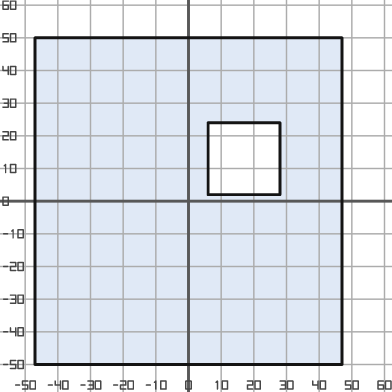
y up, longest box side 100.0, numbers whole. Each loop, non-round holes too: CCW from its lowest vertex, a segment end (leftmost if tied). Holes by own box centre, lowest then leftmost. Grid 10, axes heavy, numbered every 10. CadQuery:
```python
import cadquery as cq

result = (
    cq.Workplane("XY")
    .moveTo(-47.0, -50.0)
    .lineTo(47.0, -50.0)
    .lineTo(47.0, 50.0)
    .lineTo(-47.0, 50.0)
    .close()
    .moveTo(6.0, 2.0)
    .lineTo(28.0, 2.0)
    .lineTo(28.0, 24.0)
    .lineTo(6.0, 24.0)
    .close()
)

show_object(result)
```